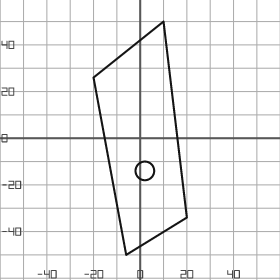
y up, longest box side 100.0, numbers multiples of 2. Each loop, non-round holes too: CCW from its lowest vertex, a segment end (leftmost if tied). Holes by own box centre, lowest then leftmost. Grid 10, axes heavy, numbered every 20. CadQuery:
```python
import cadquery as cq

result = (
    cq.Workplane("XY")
    .moveTo(-6.0, -50.0)
    .lineTo(20.0, -34.0)
    .lineTo(10.0, 50.0)
    .lineTo(-20.0, 26.0)
    .close()
    .moveTo(2.0, -14.0)
    .circle(4.0)
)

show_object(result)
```